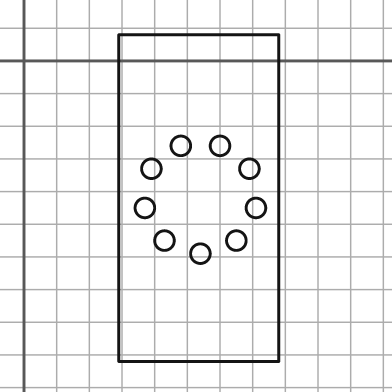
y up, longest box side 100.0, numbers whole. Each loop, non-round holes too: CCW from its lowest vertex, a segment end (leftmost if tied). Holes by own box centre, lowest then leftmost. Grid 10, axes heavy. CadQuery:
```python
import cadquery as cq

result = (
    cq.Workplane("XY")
    .moveTo(29.0, -92.0)
    .lineTo(78.0, -92.0)
    .lineTo(78.0, 8.0)
    .lineTo(29.0, 8.0)
    .close()
    .moveTo(54.0, -59.0)
    .circle(3.0)
    .moveTo(43.0, -55.0)
    .circle(3.0)
    .moveTo(65.0, -55.0)
    .circle(3.0)
    .moveTo(37.0, -45.0)
    .circle(3.0)
    .moveTo(71.0, -45.0)
    .circle(3.0)
    .moveTo(39.0, -33.0)
    .circle(3.0)
    .moveTo(69.0, -33.0)
    .circle(3.0)
    .moveTo(48.0, -26.0)
    .circle(3.0)
    .moveTo(60.0, -26.0)
    .circle(3.0)
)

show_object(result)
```